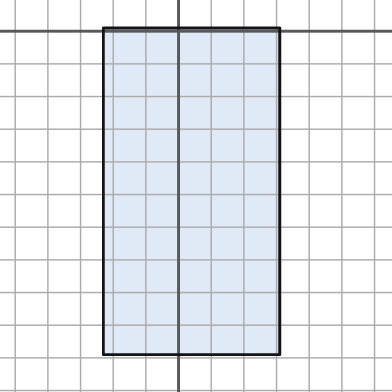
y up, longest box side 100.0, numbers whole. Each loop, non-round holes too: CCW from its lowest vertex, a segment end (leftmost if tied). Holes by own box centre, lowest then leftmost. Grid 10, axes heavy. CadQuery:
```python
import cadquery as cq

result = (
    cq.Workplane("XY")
    .moveTo(-23.0, -99.0)
    .lineTo(31.0, -99.0)
    .lineTo(31.0, 1.0)
    .lineTo(-23.0, 1.0)
    .close()
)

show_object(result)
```